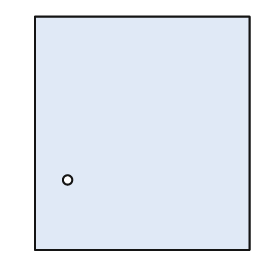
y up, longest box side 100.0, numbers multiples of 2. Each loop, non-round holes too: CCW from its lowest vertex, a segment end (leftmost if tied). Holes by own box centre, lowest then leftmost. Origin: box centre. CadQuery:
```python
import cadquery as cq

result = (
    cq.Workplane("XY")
    .moveTo(-46.0, -50.0)
    .lineTo(46.0, -50.0)
    .lineTo(46.0, 50.0)
    .lineTo(-46.0, 50.0)
    .close()
    .moveTo(-32.0, -20.0)
    .circle(2.0)
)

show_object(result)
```